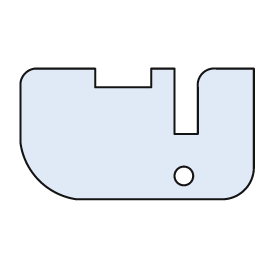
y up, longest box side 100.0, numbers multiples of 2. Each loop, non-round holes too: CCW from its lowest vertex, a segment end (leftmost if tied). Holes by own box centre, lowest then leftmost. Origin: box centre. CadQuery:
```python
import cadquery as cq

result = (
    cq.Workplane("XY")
    .moveTo(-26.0, -28.0)
    .lineTo(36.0, -28.0)
    .threePointArc((46.0, -24.0), (50.0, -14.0))
    .lineTo(50.0, 28.0)
    .lineTo(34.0, 28.0)
    .threePointArc((28.0, 26.0), (26.0, 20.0))
    .lineTo(26.0, 0.0)
    .lineTo(16.0, 0.0)
    .lineTo(16.0, 28.0)
    .lineTo(6.0, 28.0)
    .lineTo(6.0, 20.0)
    .lineTo(-18.0, 20.0)
    .lineTo(-18.0, 28.0)
    .lineTo(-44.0, 28.0)
    .threePointArc((-48.0, 26.0), (-50.0, 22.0))
    .lineTo(-50.0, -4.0)
    .threePointArc((-42.0, -20.0), (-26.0, -28.0))
    .close()
    .moveTo(20.0, -18.0)
    .circle(4.0)
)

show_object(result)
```